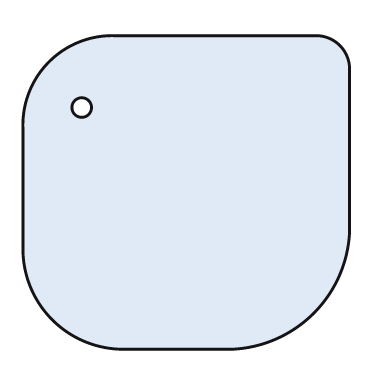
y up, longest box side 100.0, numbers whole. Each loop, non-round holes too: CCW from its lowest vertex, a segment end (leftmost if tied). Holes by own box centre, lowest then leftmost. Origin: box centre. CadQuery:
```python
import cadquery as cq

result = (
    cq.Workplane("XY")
    .moveTo(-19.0, -48.0)
    .lineTo(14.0, -48.0)
    .threePointArc((39.0, -37.0), (50.0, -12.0))
    .lineTo(50.0, 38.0)
    .threePointArc((47.0, 45.0), (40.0, 48.0))
    .lineTo(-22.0, 48.0)
    .threePointArc((-42.0, 40.0), (-50.0, 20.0))
    .lineTo(-50.0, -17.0)
    .threePointArc((-41.0, -39.0), (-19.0, -48.0))
    .close()
    .moveTo(-32.0, 26.0)
    .circle(3.0)
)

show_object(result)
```